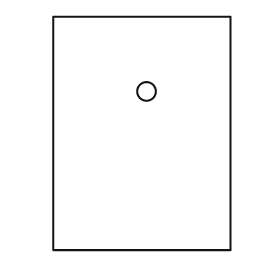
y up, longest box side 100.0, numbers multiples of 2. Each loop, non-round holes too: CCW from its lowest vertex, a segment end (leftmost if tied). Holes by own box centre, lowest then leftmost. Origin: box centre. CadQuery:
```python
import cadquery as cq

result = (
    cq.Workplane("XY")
    .moveTo(-38.0, -50.0)
    .lineTo(38.0, -50.0)
    .lineTo(38.0, 50.0)
    .lineTo(-38.0, 50.0)
    .close()
    .moveTo(2.0, 18.0)
    .circle(4.0)
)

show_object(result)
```